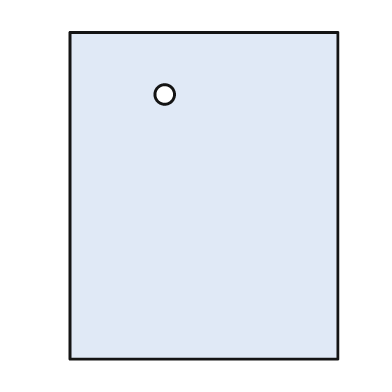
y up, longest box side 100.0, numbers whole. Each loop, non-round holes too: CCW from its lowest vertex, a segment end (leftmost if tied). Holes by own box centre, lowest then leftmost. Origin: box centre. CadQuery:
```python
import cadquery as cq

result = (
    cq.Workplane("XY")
    .moveTo(-41.0, -50.0)
    .lineTo(41.0, -50.0)
    .lineTo(41.0, 50.0)
    .lineTo(-41.0, 50.0)
    .close()
    .moveTo(-12.0, 31.0)
    .circle(3.0)
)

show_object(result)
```